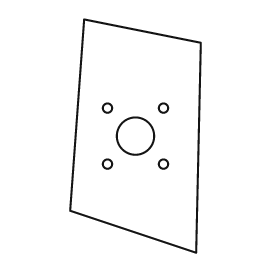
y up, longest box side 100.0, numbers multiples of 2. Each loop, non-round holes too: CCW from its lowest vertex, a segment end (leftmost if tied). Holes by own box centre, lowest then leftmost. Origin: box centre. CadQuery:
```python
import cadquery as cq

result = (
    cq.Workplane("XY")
    .moveTo(26.0, -50.0)
    .lineTo(28.0, 40.0)
    .lineTo(-22.0, 50.0)
    .lineTo(-28.0, -32.0)
    .close()
    .moveTo(-12.0, -12.0)
    .circle(2.0)
    .moveTo(12.0, -12.0)
    .circle(2.0)
    .moveTo(0.0, 0.0)
    .circle(8.0)
    .moveTo(-12.0, 12.0)
    .circle(2.0)
    .moveTo(12.0, 12.0)
    .circle(2.0)
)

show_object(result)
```